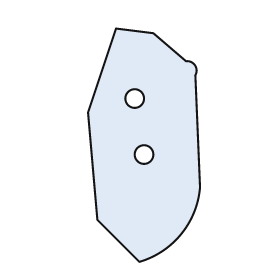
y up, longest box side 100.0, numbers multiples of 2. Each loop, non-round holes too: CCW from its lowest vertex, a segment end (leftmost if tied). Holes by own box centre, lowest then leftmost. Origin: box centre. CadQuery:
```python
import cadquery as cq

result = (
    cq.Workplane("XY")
    .moveTo(-2.0, -50.0)
    .threePointArc((16.0, -38.0), (24.0, -18.0))
    .lineTo(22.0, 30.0)
    .threePointArc((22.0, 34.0), (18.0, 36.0))
    .lineTo(4.0, 48.0)
    .lineTo(-12.0, 50.0)
    .lineTo(-24.0, 14.0)
    .lineTo(-20.0, -32.0)
    .close()
    .moveTo(0.0, -4.0)
    .circle(4.0)
    .moveTo(-4.0, 20.0)
    .circle(4.0)
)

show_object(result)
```